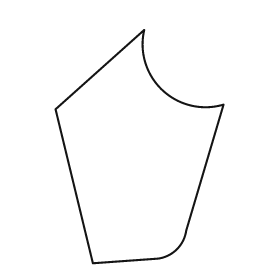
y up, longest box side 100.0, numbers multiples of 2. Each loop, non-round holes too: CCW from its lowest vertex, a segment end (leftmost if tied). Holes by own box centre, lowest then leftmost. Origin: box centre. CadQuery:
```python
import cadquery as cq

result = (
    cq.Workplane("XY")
    .moveTo(-20.0, -50.0)
    .lineTo(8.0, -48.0)
    .threePointArc((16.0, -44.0), (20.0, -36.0))
    .lineTo(36.0, 18.0)
    .threePointArc((10.0, 24.0), (2.0, 50.0))
    .lineTo(-36.0, 16.0)
    .close()
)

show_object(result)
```